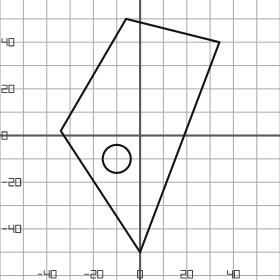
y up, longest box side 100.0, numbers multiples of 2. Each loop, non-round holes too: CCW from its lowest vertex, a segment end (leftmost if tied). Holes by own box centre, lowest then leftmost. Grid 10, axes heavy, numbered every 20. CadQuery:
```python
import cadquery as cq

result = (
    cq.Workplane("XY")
    .moveTo(0.0, -50.0)
    .lineTo(34.0, 40.0)
    .lineTo(-6.0, 50.0)
    .lineTo(-34.0, 2.0)
    .close()
    .moveTo(-10.0, -10.0)
    .circle(6.0)
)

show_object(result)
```